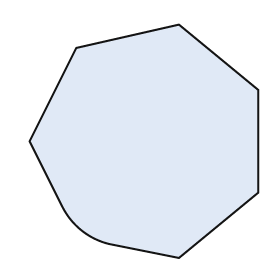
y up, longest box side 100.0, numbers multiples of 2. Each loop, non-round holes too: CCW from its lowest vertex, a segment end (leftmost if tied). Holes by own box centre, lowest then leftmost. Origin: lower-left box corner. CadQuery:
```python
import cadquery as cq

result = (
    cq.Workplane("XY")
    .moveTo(64.0, 0.0)
    .lineTo(98.0, 28.0)
    .lineTo(98.0, 72.0)
    .lineTo(64.0, 100.0)
    .lineTo(20.0, 90.0)
    .lineTo(0.0, 50.0)
    .lineTo(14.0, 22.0)
    .threePointArc((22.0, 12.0), (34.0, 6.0))
    .close()
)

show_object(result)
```